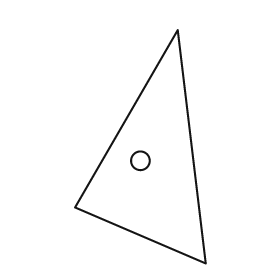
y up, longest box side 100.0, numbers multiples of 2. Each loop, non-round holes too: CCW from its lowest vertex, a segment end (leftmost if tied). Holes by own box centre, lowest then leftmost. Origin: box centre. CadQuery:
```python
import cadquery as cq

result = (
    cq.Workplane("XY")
    .moveTo(28.0, -50.0)
    .lineTo(16.0, 50.0)
    .lineTo(-28.0, -26.0)
    .close()
    .moveTo(0.0, -6.0)
    .circle(4.0)
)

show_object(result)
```